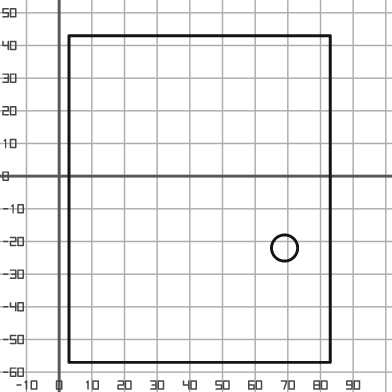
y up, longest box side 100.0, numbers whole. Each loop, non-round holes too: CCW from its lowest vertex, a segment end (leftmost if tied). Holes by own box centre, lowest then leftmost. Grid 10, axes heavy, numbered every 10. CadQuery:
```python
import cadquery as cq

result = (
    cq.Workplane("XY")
    .moveTo(3.0, -57.0)
    .lineTo(83.0, -57.0)
    .lineTo(83.0, 43.0)
    .lineTo(3.0, 43.0)
    .close()
    .moveTo(69.0, -22.0)
    .circle(4.0)
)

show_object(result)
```